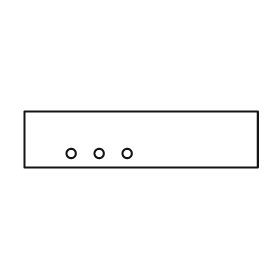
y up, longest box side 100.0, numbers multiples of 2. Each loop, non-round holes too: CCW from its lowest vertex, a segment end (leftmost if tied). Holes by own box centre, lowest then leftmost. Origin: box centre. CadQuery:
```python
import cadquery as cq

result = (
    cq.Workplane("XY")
    .moveTo(-50.0, -12.0)
    .lineTo(50.0, -12.0)
    .lineTo(50.0, 12.0)
    .lineTo(-50.0, 12.0)
    .close()
    .moveTo(-30.0, -6.0)
    .circle(2.0)
    .moveTo(-18.0, -6.0)
    .circle(2.0)
    .moveTo(-6.0, -6.0)
    .circle(2.0)
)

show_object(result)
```